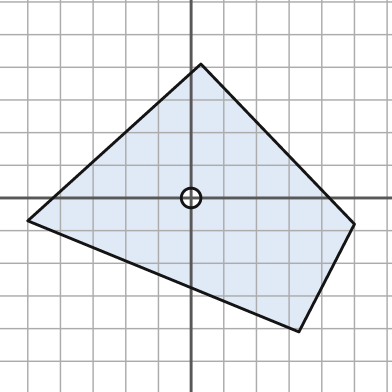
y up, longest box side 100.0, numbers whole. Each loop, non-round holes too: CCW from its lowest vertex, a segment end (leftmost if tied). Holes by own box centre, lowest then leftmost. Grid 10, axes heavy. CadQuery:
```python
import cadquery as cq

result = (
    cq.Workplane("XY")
    .moveTo(33.0, -41.0)
    .lineTo(50.0, -8.0)
    .lineTo(3.0, 41.0)
    .lineTo(-50.0, -7.0)
    .close()
    .moveTo(0.0, 0.0)
    .circle(3.0)
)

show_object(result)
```